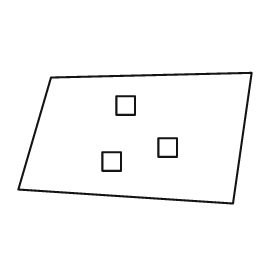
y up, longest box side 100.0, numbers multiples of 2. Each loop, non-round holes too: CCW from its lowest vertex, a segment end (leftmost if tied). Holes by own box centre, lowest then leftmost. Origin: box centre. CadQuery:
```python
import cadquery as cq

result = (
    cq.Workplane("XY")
    .moveTo(42.0, -28.0)
    .lineTo(50.0, 28.0)
    .lineTo(-36.0, 26.0)
    .lineTo(-50.0, -22.0)
    .close()
    .moveTo(-14.0, -14.0)
    .lineTo(-6.0, -14.0)
    .lineTo(-6.0, -6.0)
    .lineTo(-14.0, -6.0)
    .close()
    .moveTo(10.0, -8.0)
    .lineTo(18.0, -8.0)
    .lineTo(18.0, 0.0)
    .lineTo(10.0, 0.0)
    .close()
    .moveTo(-8.0, 10.0)
    .lineTo(0.0, 10.0)
    .lineTo(0.0, 18.0)
    .lineTo(-8.0, 18.0)
    .close()
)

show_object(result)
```